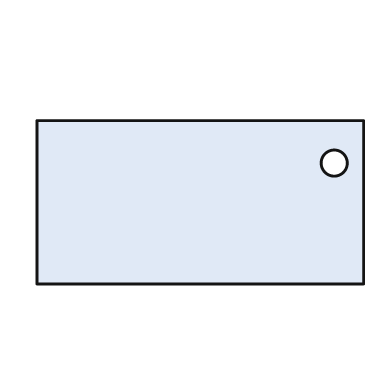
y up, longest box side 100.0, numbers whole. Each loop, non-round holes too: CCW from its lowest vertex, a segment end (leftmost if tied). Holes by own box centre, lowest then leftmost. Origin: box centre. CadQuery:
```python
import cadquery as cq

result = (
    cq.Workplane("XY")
    .moveTo(-50.0, -25.0)
    .lineTo(50.0, -25.0)
    .lineTo(50.0, 25.0)
    .lineTo(-50.0, 25.0)
    .close()
    .moveTo(41.0, 12.0)
    .circle(4.0)
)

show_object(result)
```